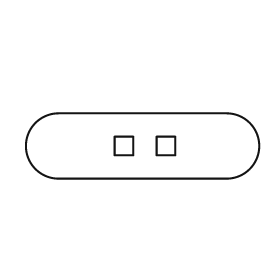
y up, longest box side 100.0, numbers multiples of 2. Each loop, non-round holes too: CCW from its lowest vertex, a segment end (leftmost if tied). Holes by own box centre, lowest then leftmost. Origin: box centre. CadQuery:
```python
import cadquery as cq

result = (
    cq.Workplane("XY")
    .moveTo(-36.0, -14.0)
    .lineTo(36.0, -14.0)
    .threePointArc((50.0, 0.0), (36.0, 14.0))
    .lineTo(-36.0, 14.0)
    .threePointArc((-50.0, 0.0), (-36.0, -14.0))
    .close()
    .moveTo(-12.0, -4.0)
    .lineTo(-4.0, -4.0)
    .lineTo(-4.0, 4.0)
    .lineTo(-12.0, 4.0)
    .close()
    .moveTo(6.0, -4.0)
    .lineTo(14.0, -4.0)
    .lineTo(14.0, 4.0)
    .lineTo(6.0, 4.0)
    .close()
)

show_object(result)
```